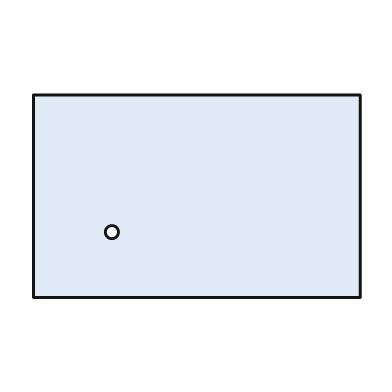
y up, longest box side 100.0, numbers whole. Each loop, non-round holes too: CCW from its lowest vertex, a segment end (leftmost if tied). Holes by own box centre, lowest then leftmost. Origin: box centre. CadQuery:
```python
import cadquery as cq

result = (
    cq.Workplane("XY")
    .moveTo(-50.0, -31.0)
    .lineTo(50.0, -31.0)
    .lineTo(50.0, 31.0)
    .lineTo(-50.0, 31.0)
    .close()
    .moveTo(-26.0, -11.0)
    .circle(2.0)
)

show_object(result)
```